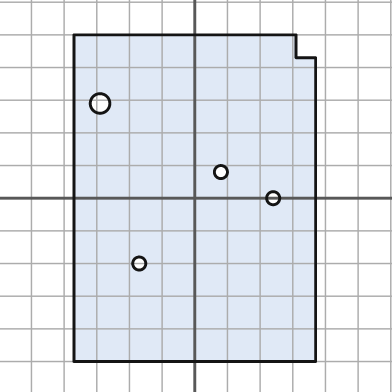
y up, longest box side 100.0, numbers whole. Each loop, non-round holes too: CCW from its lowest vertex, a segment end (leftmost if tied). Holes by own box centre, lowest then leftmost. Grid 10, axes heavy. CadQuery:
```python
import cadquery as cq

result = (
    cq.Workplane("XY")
    .moveTo(-37.0, -50.0)
    .lineTo(37.0, -50.0)
    .lineTo(37.0, 43.0)
    .lineTo(31.0, 43.0)
    .lineTo(31.0, 50.0)
    .lineTo(-37.0, 50.0)
    .close()
    .moveTo(-17.0, -20.0)
    .circle(2.0)
    .moveTo(24.0, 0.0)
    .circle(2.0)
    .moveTo(8.0, 8.0)
    .circle(2.0)
    .moveTo(-29.0, 29.0)
    .circle(3.0)
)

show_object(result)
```